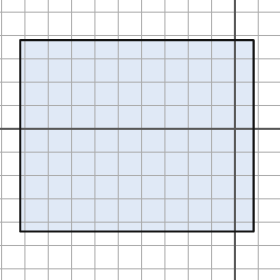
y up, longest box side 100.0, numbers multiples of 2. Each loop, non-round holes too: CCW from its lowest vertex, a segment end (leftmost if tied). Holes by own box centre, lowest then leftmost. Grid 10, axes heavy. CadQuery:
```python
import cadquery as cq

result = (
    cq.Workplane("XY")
    .moveTo(-92.0, -44.0)
    .lineTo(8.0, -44.0)
    .lineTo(8.0, 38.0)
    .lineTo(-92.0, 38.0)
    .close()
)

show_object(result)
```